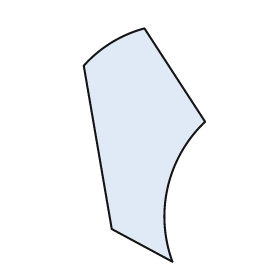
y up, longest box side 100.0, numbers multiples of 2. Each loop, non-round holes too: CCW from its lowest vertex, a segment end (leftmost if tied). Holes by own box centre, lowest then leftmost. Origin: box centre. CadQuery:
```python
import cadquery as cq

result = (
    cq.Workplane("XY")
    .moveTo(12.0, -50.0)
    .threePointArc((10.0, -18.0), (26.0, 10.0))
    .lineTo(0.0, 50.0)
    .threePointArc((-14.0, 44.0), (-26.0, 34.0))
    .lineTo(-14.0, -36.0)
    .close()
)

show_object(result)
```